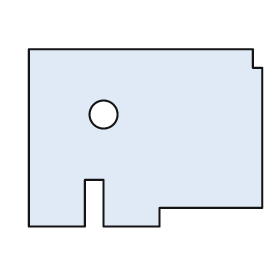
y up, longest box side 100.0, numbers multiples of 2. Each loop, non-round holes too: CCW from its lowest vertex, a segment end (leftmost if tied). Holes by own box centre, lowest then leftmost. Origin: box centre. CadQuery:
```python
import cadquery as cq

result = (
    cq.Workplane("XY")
    .moveTo(-50.0, -38.0)
    .lineTo(-26.0, -38.0)
    .lineTo(-26.0, -18.0)
    .lineTo(-18.0, -18.0)
    .lineTo(-18.0, -38.0)
    .lineTo(6.0, -38.0)
    .lineTo(6.0, -30.0)
    .lineTo(50.0, -30.0)
    .lineTo(50.0, 30.0)
    .lineTo(46.0, 30.0)
    .lineTo(46.0, 38.0)
    .lineTo(-50.0, 38.0)
    .close()
    .moveTo(-18.0, 10.0)
    .circle(6.0)
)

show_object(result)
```